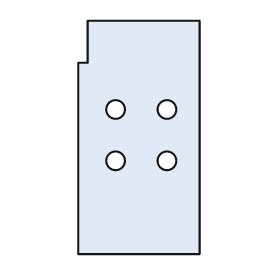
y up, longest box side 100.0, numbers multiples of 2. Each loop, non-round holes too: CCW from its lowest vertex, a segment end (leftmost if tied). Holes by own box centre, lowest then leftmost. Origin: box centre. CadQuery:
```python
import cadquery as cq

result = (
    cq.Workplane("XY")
    .moveTo(-26.0, -50.0)
    .lineTo(26.0, -50.0)
    .lineTo(26.0, 50.0)
    .lineTo(-22.0, 50.0)
    .lineTo(-22.0, 32.0)
    .lineTo(-26.0, 32.0)
    .close()
    .moveTo(-10.0, -10.0)
    .circle(4.0)
    .moveTo(12.0, -10.0)
    .circle(4.0)
    .moveTo(-10.0, 12.0)
    .circle(4.0)
    .moveTo(12.0, 12.0)
    .circle(4.0)
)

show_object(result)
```